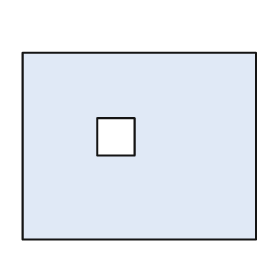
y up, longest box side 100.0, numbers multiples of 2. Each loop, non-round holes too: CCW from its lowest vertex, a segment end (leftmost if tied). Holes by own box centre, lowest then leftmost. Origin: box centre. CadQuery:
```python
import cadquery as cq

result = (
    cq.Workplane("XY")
    .moveTo(-50.0, -40.0)
    .lineTo(50.0, -40.0)
    .lineTo(50.0, 40.0)
    .lineTo(-50.0, 40.0)
    .close()
    .moveTo(-18.0, -4.0)
    .lineTo(-2.0, -4.0)
    .lineTo(-2.0, 12.0)
    .lineTo(-18.0, 12.0)
    .close()
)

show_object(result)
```